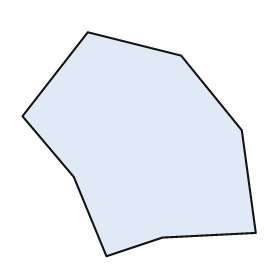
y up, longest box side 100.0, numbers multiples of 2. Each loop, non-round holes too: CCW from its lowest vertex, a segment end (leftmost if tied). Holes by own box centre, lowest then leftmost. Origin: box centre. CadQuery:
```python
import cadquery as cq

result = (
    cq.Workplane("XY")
    .moveTo(-14.0, -48.0)
    .lineTo(10.0, -40.0)
    .lineTo(50.0, -38.0)
    .lineTo(44.0, 6.0)
    .lineTo(18.0, 38.0)
    .lineTo(-22.0, 48.0)
    .lineTo(-50.0, 12.0)
    .lineTo(-28.0, -14.0)
    .close()
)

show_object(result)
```